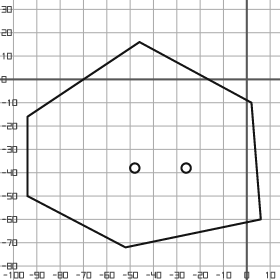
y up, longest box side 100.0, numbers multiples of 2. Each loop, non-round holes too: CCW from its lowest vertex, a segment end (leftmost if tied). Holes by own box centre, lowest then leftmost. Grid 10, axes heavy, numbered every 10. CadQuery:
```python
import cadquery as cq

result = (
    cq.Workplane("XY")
    .moveTo(-52.0, -72.0)
    .lineTo(6.0, -60.0)
    .lineTo(2.0, -10.0)
    .lineTo(-46.0, 16.0)
    .lineTo(-94.0, -16.0)
    .lineTo(-94.0, -50.0)
    .close()
    .moveTo(-48.0, -38.0)
    .circle(2.0)
    .moveTo(-26.0, -38.0)
    .circle(2.0)
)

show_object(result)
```